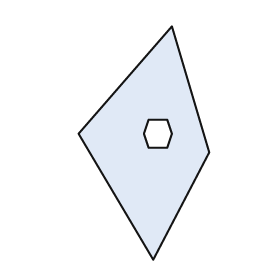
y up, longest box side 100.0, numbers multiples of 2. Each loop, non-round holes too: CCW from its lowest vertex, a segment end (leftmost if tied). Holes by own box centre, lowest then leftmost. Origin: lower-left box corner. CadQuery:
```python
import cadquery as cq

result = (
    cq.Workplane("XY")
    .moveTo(32.0, 0.0)
    .lineTo(56.0, 46.0)
    .lineTo(40.0, 100.0)
    .lineTo(0.0, 54.0)
    .close()
    .moveTo(30.0, 48.0)
    .lineTo(38.0, 48.0)
    .lineTo(40.0, 54.0)
    .lineTo(38.0, 60.0)
    .lineTo(30.0, 60.0)
    .lineTo(28.0, 54.0)
    .close()
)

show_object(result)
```